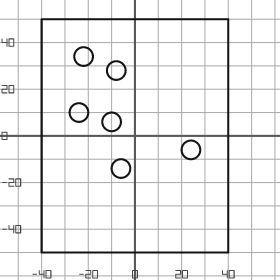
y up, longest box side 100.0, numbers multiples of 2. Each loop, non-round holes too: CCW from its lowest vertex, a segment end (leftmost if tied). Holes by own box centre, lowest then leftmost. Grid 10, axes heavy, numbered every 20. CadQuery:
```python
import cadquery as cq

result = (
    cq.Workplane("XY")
    .moveTo(-40.0, -50.0)
    .lineTo(40.0, -50.0)
    .lineTo(40.0, 50.0)
    .lineTo(-40.0, 50.0)
    .close()
    .moveTo(-6.0, -14.0)
    .circle(4.0)
    .moveTo(24.0, -6.0)
    .circle(4.0)
    .moveTo(-10.0, 6.0)
    .circle(4.0)
    .moveTo(-24.0, 10.0)
    .circle(4.0)
    .moveTo(-8.0, 28.0)
    .circle(4.0)
    .moveTo(-22.0, 34.0)
    .circle(4.0)
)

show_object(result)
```